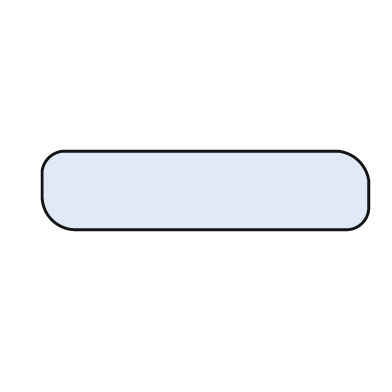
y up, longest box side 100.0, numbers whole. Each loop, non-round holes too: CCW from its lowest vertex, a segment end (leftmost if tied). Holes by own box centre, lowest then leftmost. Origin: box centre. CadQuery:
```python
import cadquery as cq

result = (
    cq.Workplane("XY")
    .moveTo(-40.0, -12.0)
    .lineTo(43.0, -12.0)
    .threePointArc((48.0, -10.0), (50.0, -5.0))
    .lineTo(50.0, 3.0)
    .threePointArc((47.0, 9.0), (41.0, 12.0))
    .lineTo(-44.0, 12.0)
    .threePointArc((-48.0, 10.0), (-50.0, 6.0))
    .lineTo(-50.0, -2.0)
    .threePointArc((-47.0, -9.0), (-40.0, -12.0))
    .close()
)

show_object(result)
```